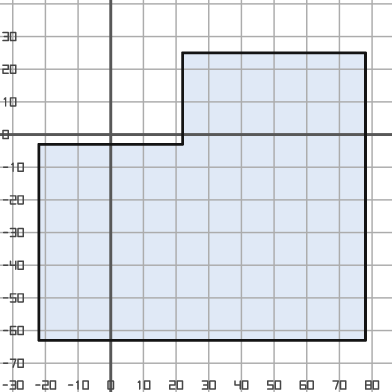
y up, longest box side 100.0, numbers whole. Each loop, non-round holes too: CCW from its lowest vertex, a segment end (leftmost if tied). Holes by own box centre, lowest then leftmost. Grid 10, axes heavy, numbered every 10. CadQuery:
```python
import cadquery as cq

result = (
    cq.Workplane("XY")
    .moveTo(-22.0, -63.0)
    .lineTo(78.0, -63.0)
    .lineTo(78.0, 25.0)
    .lineTo(22.0, 25.0)
    .lineTo(22.0, -3.0)
    .lineTo(-22.0, -3.0)
    .close()
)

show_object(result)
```